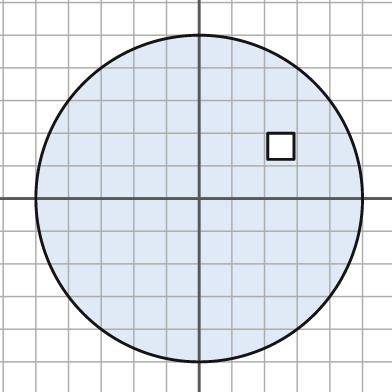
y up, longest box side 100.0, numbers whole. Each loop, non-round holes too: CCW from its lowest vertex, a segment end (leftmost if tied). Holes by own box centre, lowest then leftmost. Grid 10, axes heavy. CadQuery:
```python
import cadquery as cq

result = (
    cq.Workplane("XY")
    .moveTo(0.0, 0.0)
    .circle(50.0)
    .moveTo(21.0, 12.0)
    .lineTo(29.0, 12.0)
    .lineTo(29.0, 20.0)
    .lineTo(21.0, 20.0)
    .close()
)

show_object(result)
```